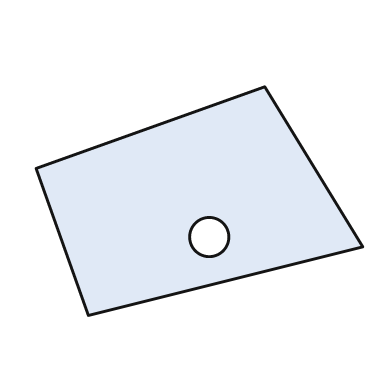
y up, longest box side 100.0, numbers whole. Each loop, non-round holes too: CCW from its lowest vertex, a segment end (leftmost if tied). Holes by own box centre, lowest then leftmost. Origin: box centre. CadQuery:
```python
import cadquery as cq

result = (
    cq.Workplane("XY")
    .moveTo(-34.0, -35.0)
    .lineTo(50.0, -14.0)
    .lineTo(20.0, 35.0)
    .lineTo(-50.0, 10.0)
    .close()
    .moveTo(3.0, -11.0)
    .circle(6.0)
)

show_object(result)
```